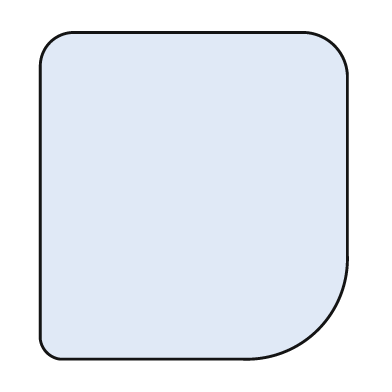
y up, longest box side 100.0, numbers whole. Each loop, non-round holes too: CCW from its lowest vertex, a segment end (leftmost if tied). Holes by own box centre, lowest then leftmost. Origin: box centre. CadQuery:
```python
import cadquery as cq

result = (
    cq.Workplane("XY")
    .moveTo(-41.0, -50.0)
    .lineTo(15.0, -50.0)
    .threePointArc((38.0, -41.0), (47.0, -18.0))
    .lineTo(47.0, 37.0)
    .threePointArc((43.0, 46.0), (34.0, 50.0))
    .lineTo(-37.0, 50.0)
    .threePointArc((-44.0, 47.0), (-47.0, 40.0))
    .lineTo(-47.0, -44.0)
    .threePointArc((-45.0, -48.0), (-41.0, -50.0))
    .close()
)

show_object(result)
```